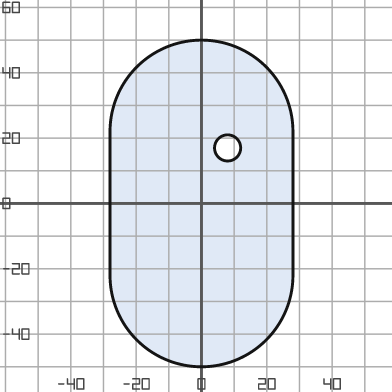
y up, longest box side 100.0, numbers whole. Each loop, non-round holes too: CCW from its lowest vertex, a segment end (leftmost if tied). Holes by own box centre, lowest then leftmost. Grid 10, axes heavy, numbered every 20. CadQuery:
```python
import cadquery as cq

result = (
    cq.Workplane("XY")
    .moveTo(-28.0, -22.0)
    .threePointArc((0.0, -50.0), (28.0, -22.0))
    .lineTo(28.0, 22.0)
    .threePointArc((0.0, 50.0), (-28.0, 22.0))
    .close()
    .moveTo(8.0, 17.0)
    .circle(4.0)
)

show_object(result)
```